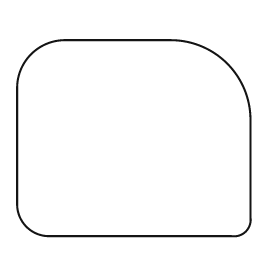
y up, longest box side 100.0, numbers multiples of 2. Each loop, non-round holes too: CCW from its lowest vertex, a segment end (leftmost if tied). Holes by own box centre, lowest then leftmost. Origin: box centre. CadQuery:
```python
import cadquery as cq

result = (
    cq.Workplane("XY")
    .moveTo(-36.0, -42.0)
    .lineTo(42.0, -42.0)
    .threePointArc((48.0, -40.0), (50.0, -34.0))
    .lineTo(50.0, 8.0)
    .threePointArc((40.0, 32.0), (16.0, 42.0))
    .lineTo(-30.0, 42.0)
    .threePointArc((-44.0, 36.0), (-50.0, 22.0))
    .lineTo(-50.0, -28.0)
    .threePointArc((-46.0, -38.0), (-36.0, -42.0))
    .close()
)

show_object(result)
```